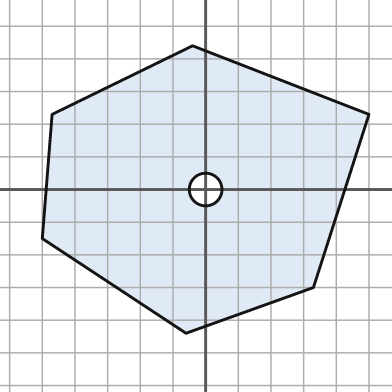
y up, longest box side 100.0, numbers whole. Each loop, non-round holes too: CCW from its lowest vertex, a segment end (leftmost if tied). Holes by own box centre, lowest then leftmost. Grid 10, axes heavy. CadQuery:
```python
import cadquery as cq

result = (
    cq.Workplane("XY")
    .moveTo(-6.0, -44.0)
    .lineTo(33.0, -30.0)
    .lineTo(50.0, 23.0)
    .lineTo(-4.0, 44.0)
    .lineTo(-47.0, 23.0)
    .lineTo(-50.0, -15.0)
    .close()
    .moveTo(0.0, 0.0)
    .circle(5.0)
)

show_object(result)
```